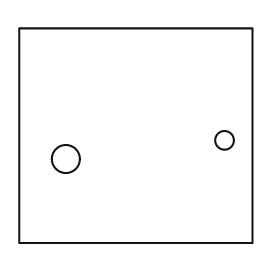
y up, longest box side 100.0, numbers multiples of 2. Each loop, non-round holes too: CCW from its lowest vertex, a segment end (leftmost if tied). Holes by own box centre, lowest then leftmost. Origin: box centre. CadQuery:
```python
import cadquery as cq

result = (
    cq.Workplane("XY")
    .moveTo(-50.0, -46.0)
    .lineTo(50.0, -46.0)
    .lineTo(50.0, 46.0)
    .lineTo(-50.0, 46.0)
    .close()
    .moveTo(-30.0, -10.0)
    .circle(6.0)
    .moveTo(38.0, -2.0)
    .circle(4.0)
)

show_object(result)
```